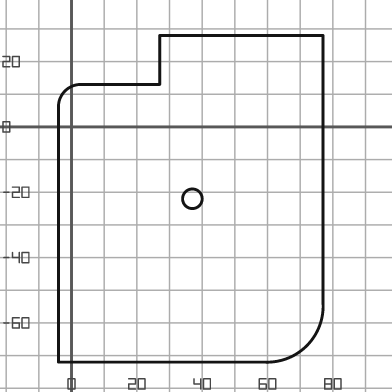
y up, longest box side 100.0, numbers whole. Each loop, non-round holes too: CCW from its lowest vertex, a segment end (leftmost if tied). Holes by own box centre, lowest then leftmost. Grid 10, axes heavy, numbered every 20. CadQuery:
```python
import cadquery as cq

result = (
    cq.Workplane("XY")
    .moveTo(-4.0, -72.0)
    .lineTo(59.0, -72.0)
    .threePointArc((72.0, -67.0), (77.0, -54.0))
    .lineTo(77.0, 28.0)
    .lineTo(27.0, 28.0)
    .lineTo(27.0, 13.0)
    .lineTo(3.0, 13.0)
    .threePointArc((-2.0, 11.0), (-4.0, 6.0))
    .close()
    .moveTo(37.0, -22.0)
    .circle(3.0)
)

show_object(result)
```